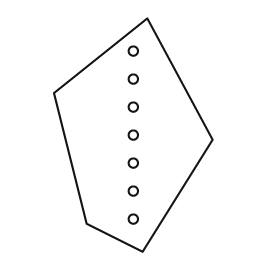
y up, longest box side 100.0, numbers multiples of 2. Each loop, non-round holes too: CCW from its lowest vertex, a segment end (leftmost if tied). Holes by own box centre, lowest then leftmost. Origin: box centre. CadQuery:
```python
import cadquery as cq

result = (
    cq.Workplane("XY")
    .moveTo(4.0, -50.0)
    .lineTo(34.0, -2.0)
    .lineTo(6.0, 50.0)
    .lineTo(-34.0, 18.0)
    .lineTo(-20.0, -38.0)
    .close()
    .moveTo(0.0, -36.0)
    .circle(2.0)
    .moveTo(0.0, -24.0)
    .circle(2.0)
    .moveTo(0.0, -12.0)
    .circle(2.0)
    .moveTo(0.0, 0.0)
    .circle(2.0)
    .moveTo(0.0, 12.0)
    .circle(2.0)
    .moveTo(0.0, 24.0)
    .circle(2.0)
    .moveTo(0.0, 36.0)
    .circle(2.0)
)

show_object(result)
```